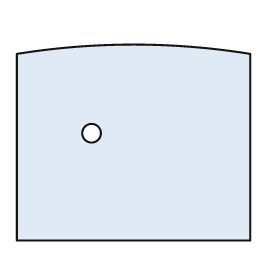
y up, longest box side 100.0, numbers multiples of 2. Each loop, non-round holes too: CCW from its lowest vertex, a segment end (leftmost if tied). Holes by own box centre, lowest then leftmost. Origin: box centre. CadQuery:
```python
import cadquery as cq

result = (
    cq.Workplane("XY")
    .moveTo(-50.0, -42.0)
    .lineTo(50.0, -42.0)
    .lineTo(50.0, 38.0)
    .threePointArc((0.0, 42.0), (-50.0, 38.0))
    .close()
    .moveTo(-18.0, 4.0)
    .circle(4.0)
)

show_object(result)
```